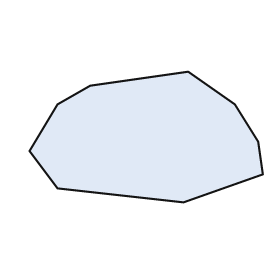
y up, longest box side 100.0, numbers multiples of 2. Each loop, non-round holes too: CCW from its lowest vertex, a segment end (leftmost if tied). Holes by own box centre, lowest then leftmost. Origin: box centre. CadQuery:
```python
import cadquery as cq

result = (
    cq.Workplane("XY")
    .moveTo(16.0, -28.0)
    .lineTo(50.0, -16.0)
    .lineTo(48.0, -2.0)
    .lineTo(38.0, 14.0)
    .lineTo(18.0, 28.0)
    .lineTo(-24.0, 22.0)
    .lineTo(-38.0, 14.0)
    .lineTo(-50.0, -6.0)
    .lineTo(-38.0, -22.0)
    .close()
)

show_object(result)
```